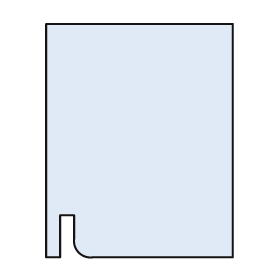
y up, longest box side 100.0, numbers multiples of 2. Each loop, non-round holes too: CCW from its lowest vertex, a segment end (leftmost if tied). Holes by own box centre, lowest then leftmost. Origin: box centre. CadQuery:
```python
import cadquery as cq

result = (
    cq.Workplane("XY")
    .moveTo(-40.0, -50.0)
    .lineTo(-34.0, -50.0)
    .lineTo(-34.0, -32.0)
    .lineTo(-28.0, -32.0)
    .lineTo(-28.0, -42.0)
    .threePointArc((-26.0, -48.0), (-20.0, -50.0))
    .lineTo(40.0, -50.0)
    .lineTo(40.0, 50.0)
    .lineTo(-40.0, 50.0)
    .close()
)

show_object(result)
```